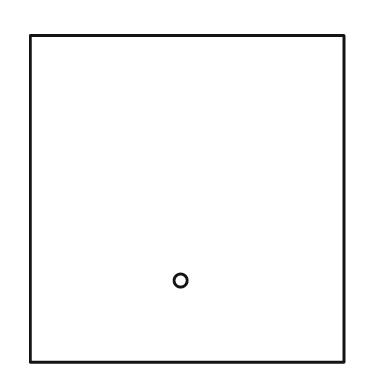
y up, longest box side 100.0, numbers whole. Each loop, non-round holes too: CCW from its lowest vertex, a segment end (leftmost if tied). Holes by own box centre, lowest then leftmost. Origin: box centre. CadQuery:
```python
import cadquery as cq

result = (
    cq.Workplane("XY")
    .moveTo(-48.0, -50.0)
    .lineTo(48.0, -50.0)
    .lineTo(48.0, 50.0)
    .lineTo(-48.0, 50.0)
    .close()
    .moveTo(-2.0, -25.0)
    .circle(2.0)
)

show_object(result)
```